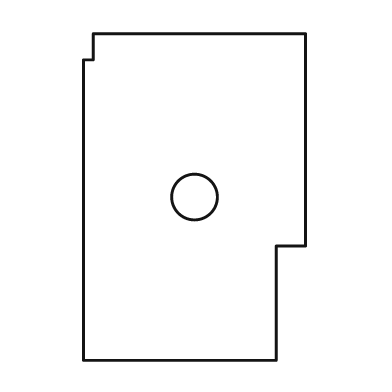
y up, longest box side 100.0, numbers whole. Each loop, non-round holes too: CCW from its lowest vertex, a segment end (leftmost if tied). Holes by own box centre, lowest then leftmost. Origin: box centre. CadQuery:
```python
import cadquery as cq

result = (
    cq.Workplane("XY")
    .moveTo(-34.0, -50.0)
    .lineTo(25.0, -50.0)
    .lineTo(25.0, -15.0)
    .lineTo(34.0, -15.0)
    .lineTo(34.0, 50.0)
    .lineTo(-31.0, 50.0)
    .lineTo(-31.0, 42.0)
    .lineTo(-34.0, 42.0)
    .close()
    .moveTo(0.0, 0.0)
    .circle(7.0)
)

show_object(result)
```